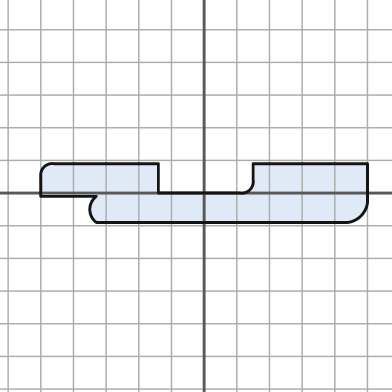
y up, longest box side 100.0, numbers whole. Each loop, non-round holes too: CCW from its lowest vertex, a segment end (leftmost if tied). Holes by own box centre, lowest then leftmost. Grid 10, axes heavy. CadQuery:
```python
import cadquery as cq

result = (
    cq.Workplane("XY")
    .moveTo(-33.0, -9.0)
    .lineTo(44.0, -9.0)
    .threePointArc((48.0, -7.0), (50.0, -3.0))
    .lineTo(50.0, 9.0)
    .lineTo(15.0, 9.0)
    .lineTo(15.0, 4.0)
    .threePointArc((14.0, 1.0), (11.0, 0.0))
    .lineTo(-14.0, 0.0)
    .lineTo(-14.0, 9.0)
    .lineTo(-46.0, 9.0)
    .threePointArc((-49.0, 8.0), (-50.0, 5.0))
    .lineTo(-50.0, -1.0)
    .lineTo(-33.0, -1.0)
    .threePointArc((-35.0, -5.0), (-33.0, -9.0))
    .close()
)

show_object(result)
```